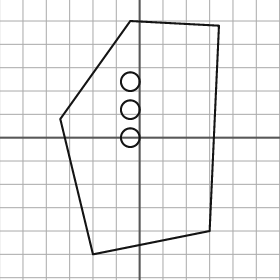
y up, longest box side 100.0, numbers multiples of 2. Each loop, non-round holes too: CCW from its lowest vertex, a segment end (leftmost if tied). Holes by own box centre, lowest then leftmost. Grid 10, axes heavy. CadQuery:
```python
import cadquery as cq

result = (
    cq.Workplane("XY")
    .moveTo(-20.0, -50.0)
    .lineTo(30.0, -40.0)
    .lineTo(34.0, 48.0)
    .lineTo(-4.0, 50.0)
    .lineTo(-34.0, 8.0)
    .close()
    .moveTo(-4.0, 0.0)
    .circle(4.0)
    .moveTo(-4.0, 12.0)
    .circle(4.0)
    .moveTo(-4.0, 24.0)
    .circle(4.0)
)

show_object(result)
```